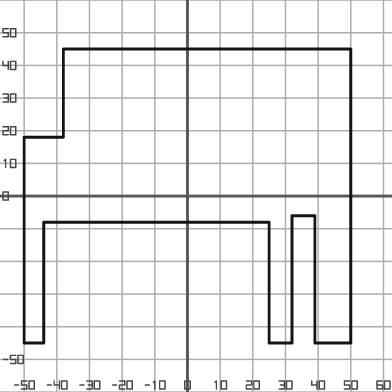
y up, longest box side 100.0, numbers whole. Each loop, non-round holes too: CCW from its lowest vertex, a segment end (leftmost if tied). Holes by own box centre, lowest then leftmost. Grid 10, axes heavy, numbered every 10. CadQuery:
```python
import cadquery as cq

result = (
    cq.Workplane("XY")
    .moveTo(-50.0, -45.0)
    .lineTo(-44.0, -45.0)
    .lineTo(-44.0, -8.0)
    .lineTo(25.0, -8.0)
    .lineTo(25.0, -45.0)
    .lineTo(32.0, -45.0)
    .lineTo(32.0, -6.0)
    .lineTo(39.0, -6.0)
    .lineTo(39.0, -45.0)
    .lineTo(50.0, -45.0)
    .lineTo(50.0, 45.0)
    .lineTo(-38.0, 45.0)
    .lineTo(-38.0, 18.0)
    .lineTo(-50.0, 18.0)
    .close()
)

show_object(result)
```